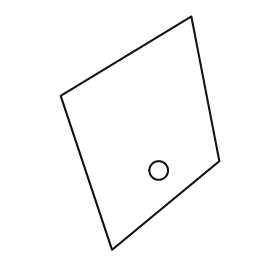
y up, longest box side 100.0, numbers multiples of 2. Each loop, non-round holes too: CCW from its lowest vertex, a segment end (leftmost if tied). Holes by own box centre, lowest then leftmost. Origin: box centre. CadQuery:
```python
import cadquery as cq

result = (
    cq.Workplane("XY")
    .moveTo(-12.0, -50.0)
    .lineTo(34.0, -12.0)
    .lineTo(22.0, 50.0)
    .lineTo(-34.0, 16.0)
    .close()
    .moveTo(8.0, -16.0)
    .circle(4.0)
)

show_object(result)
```